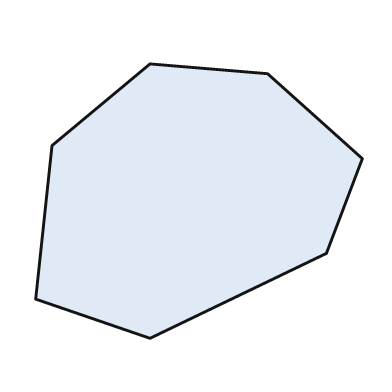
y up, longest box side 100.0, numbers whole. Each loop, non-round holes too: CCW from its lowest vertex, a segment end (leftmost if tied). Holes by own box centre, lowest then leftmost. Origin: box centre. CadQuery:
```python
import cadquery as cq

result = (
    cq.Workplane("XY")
    .moveTo(-15.0, -42.0)
    .lineTo(39.0, -16.0)
    .lineTo(50.0, 13.0)
    .lineTo(21.0, 39.0)
    .lineTo(-15.0, 42.0)
    .lineTo(-45.0, 17.0)
    .lineTo(-50.0, -30.0)
    .close()
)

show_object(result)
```